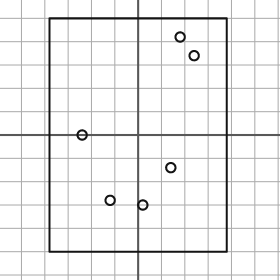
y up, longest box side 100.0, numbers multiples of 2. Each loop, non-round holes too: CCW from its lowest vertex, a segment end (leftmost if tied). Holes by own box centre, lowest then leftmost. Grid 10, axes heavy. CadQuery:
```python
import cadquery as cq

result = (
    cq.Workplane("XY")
    .moveTo(-38.0, -50.0)
    .lineTo(38.0, -50.0)
    .lineTo(38.0, 50.0)
    .lineTo(-38.0, 50.0)
    .close()
    .moveTo(2.0, -30.0)
    .circle(2.0)
    .moveTo(-12.0, -28.0)
    .circle(2.0)
    .moveTo(14.0, -14.0)
    .circle(2.0)
    .moveTo(-24.0, 0.0)
    .circle(2.0)
    .moveTo(24.0, 34.0)
    .circle(2.0)
    .moveTo(18.0, 42.0)
    .circle(2.0)
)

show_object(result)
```